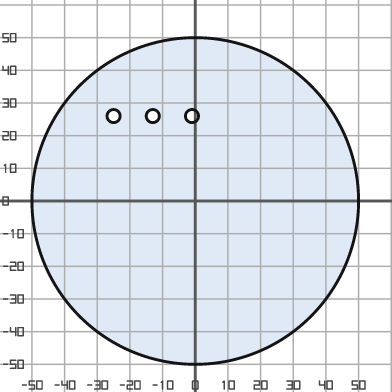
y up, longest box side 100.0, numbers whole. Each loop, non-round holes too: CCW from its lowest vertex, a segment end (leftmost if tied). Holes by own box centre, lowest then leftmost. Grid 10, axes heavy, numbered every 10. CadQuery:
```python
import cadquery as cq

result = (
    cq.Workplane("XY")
    .moveTo(0.0, 0.0)
    .circle(50.0)
    .moveTo(-25.0, 26.0)
    .circle(2.0)
    .moveTo(-13.0, 26.0)
    .circle(2.0)
    .moveTo(-1.0, 26.0)
    .circle(2.0)
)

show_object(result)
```